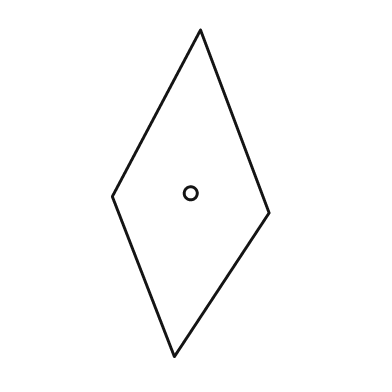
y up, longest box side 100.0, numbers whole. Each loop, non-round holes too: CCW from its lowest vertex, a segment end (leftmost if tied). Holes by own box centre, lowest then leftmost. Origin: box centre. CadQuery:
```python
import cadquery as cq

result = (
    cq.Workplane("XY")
    .moveTo(-5.0, -50.0)
    .lineTo(24.0, -6.0)
    .lineTo(3.0, 50.0)
    .lineTo(-24.0, -1.0)
    .close()
    .moveTo(0.0, 0.0)
    .circle(2.0)
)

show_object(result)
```